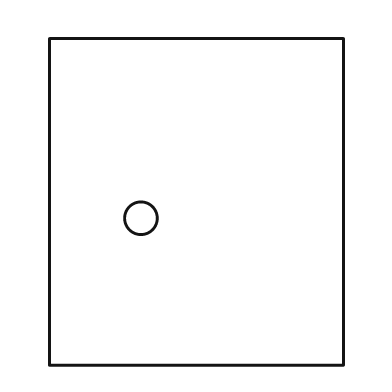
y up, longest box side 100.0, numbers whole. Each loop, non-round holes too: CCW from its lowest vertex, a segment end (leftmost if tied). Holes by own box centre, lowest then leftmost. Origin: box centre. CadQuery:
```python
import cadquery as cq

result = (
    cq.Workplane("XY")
    .moveTo(-45.0, -50.0)
    .lineTo(45.0, -50.0)
    .lineTo(45.0, 50.0)
    .lineTo(-45.0, 50.0)
    .close()
    .moveTo(-17.0, -5.0)
    .circle(5.0)
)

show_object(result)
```